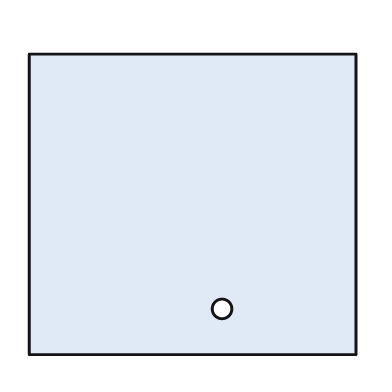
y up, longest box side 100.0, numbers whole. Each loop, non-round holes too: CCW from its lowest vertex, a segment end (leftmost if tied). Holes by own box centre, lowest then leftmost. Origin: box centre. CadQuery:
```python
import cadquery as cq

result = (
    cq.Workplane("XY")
    .moveTo(-50.0, -46.0)
    .lineTo(50.0, -46.0)
    .lineTo(50.0, 46.0)
    .lineTo(-50.0, 46.0)
    .close()
    .moveTo(9.0, -32.0)
    .circle(3.0)
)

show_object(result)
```